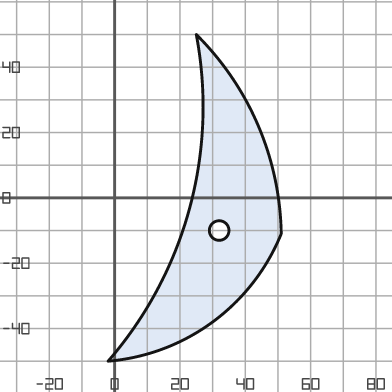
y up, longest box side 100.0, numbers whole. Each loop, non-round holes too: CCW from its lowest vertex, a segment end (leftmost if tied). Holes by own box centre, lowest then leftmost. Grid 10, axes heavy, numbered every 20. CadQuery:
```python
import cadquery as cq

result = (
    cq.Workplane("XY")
    .moveTo(-2.0, -50.0)
    .threePointArc((30.0, -38.0), (51.0, -11.0))
    .threePointArc((44.0, 22.0), (25.0, 50.0))
    .threePointArc((23.0, -3.0), (-2.0, -50.0))
    .close()
    .moveTo(32.0, -10.0)
    .circle(3.0)
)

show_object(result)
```